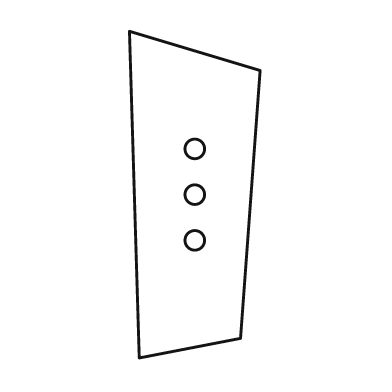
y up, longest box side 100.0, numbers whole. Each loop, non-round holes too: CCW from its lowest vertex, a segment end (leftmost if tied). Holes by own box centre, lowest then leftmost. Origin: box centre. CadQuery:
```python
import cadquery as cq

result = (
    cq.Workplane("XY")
    .moveTo(-17.0, -50.0)
    .lineTo(14.0, -44.0)
    .lineTo(20.0, 38.0)
    .lineTo(-20.0, 50.0)
    .close()
    .moveTo(0.0, -14.0)
    .circle(3.0)
    .moveTo(0.0, 0.0)
    .circle(3.0)
    .moveTo(0.0, 14.0)
    .circle(3.0)
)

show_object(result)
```